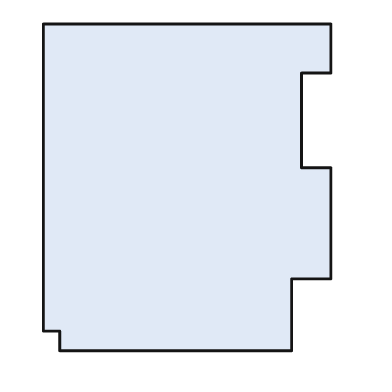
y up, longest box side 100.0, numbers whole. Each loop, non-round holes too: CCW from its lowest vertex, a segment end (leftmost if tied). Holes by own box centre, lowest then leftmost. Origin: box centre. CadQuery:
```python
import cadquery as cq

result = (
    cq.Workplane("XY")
    .moveTo(-39.0, -50.0)
    .lineTo(32.0, -50.0)
    .lineTo(32.0, -28.0)
    .lineTo(44.0, -28.0)
    .lineTo(44.0, 6.0)
    .lineTo(35.0, 6.0)
    .lineTo(35.0, 35.0)
    .lineTo(44.0, 35.0)
    .lineTo(44.0, 50.0)
    .lineTo(-44.0, 50.0)
    .lineTo(-44.0, -44.0)
    .lineTo(-39.0, -44.0)
    .close()
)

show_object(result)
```